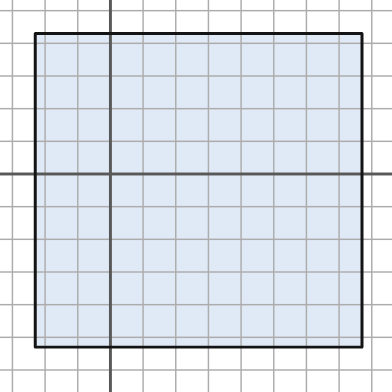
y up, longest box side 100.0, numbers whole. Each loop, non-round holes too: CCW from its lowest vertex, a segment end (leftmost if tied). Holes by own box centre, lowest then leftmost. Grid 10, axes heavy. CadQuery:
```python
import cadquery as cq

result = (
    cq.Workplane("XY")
    .moveTo(-23.0, -53.0)
    .lineTo(77.0, -53.0)
    .lineTo(77.0, 43.0)
    .lineTo(-23.0, 43.0)
    .close()
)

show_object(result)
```